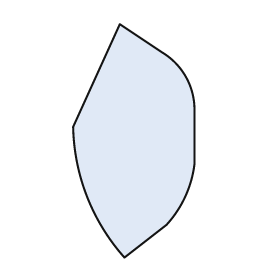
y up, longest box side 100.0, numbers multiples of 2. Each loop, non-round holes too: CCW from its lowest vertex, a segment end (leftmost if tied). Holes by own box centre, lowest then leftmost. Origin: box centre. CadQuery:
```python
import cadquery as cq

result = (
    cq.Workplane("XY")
    .moveTo(-4.0, -50.0)
    .lineTo(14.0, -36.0)
    .threePointArc((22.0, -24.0), (26.0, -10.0))
    .lineTo(26.0, 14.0)
    .threePointArc((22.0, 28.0), (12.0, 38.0))
    .lineTo(-6.0, 50.0)
    .lineTo(-26.0, 6.0)
    .threePointArc((-20.0, -24.0), (-4.0, -50.0))
    .close()
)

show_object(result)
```